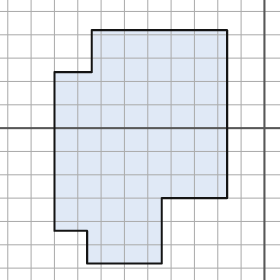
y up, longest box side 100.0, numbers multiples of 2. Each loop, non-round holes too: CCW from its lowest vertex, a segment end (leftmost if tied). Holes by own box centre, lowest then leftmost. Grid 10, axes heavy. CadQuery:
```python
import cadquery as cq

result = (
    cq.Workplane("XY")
    .moveTo(-76.0, -58.0)
    .lineTo(-44.0, -58.0)
    .lineTo(-44.0, -30.0)
    .lineTo(-16.0, -30.0)
    .lineTo(-16.0, 42.0)
    .lineTo(-74.0, 42.0)
    .lineTo(-74.0, 24.0)
    .lineTo(-90.0, 24.0)
    .lineTo(-90.0, -44.0)
    .lineTo(-76.0, -44.0)
    .close()
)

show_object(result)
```